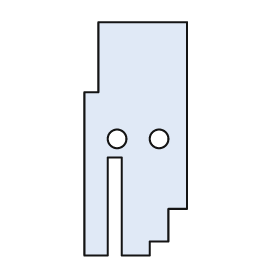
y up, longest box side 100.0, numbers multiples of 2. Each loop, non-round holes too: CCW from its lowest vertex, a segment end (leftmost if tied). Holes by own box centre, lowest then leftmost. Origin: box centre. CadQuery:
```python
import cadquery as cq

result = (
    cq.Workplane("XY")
    .moveTo(-22.0, -50.0)
    .lineTo(-12.0, -50.0)
    .lineTo(-12.0, -8.0)
    .lineTo(-6.0, -8.0)
    .lineTo(-6.0, -50.0)
    .lineTo(6.0, -50.0)
    .lineTo(6.0, -44.0)
    .lineTo(14.0, -44.0)
    .lineTo(14.0, -30.0)
    .lineTo(22.0, -30.0)
    .lineTo(22.0, 50.0)
    .lineTo(-16.0, 50.0)
    .lineTo(-16.0, 20.0)
    .lineTo(-22.0, 20.0)
    .close()
    .moveTo(-8.0, 0.0)
    .circle(4.0)
    .moveTo(10.0, 0.0)
    .circle(4.0)
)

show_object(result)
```